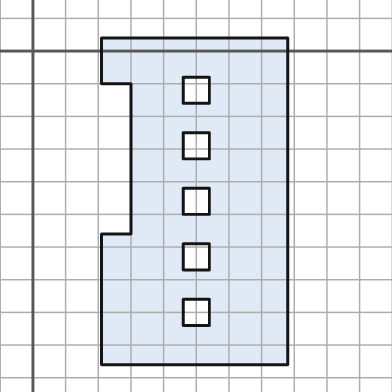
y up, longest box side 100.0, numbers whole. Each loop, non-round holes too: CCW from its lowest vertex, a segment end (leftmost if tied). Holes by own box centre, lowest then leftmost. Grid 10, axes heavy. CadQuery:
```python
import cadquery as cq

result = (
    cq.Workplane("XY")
    .moveTo(21.0, -96.0)
    .lineTo(78.0, -96.0)
    .lineTo(78.0, 4.0)
    .lineTo(21.0, 4.0)
    .lineTo(21.0, -10.0)
    .lineTo(30.0, -10.0)
    .lineTo(30.0, -56.0)
    .lineTo(21.0, -56.0)
    .close()
    .moveTo(46.0, -84.0)
    .lineTo(54.0, -84.0)
    .lineTo(54.0, -76.0)
    .lineTo(46.0, -76.0)
    .close()
    .moveTo(46.0, -67.0)
    .lineTo(54.0, -67.0)
    .lineTo(54.0, -59.0)
    .lineTo(46.0, -59.0)
    .close()
    .moveTo(46.0, -50.0)
    .lineTo(54.0, -50.0)
    .lineTo(54.0, -42.0)
    .lineTo(46.0, -42.0)
    .close()
    .moveTo(46.0, -33.0)
    .lineTo(54.0, -33.0)
    .lineTo(54.0, -25.0)
    .lineTo(46.0, -25.0)
    .close()
    .moveTo(46.0, -16.0)
    .lineTo(54.0, -16.0)
    .lineTo(54.0, -8.0)
    .lineTo(46.0, -8.0)
    .close()
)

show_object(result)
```